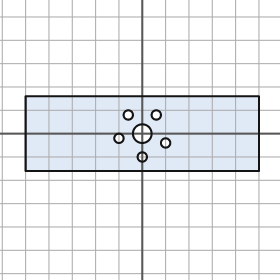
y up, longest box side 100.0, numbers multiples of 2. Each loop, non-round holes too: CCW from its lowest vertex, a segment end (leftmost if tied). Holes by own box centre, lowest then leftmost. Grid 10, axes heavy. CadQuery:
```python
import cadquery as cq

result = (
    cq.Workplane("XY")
    .moveTo(-50.0, -16.0)
    .lineTo(50.0, -16.0)
    .lineTo(50.0, 16.0)
    .lineTo(-50.0, 16.0)
    .close()
    .moveTo(0.0, -10.0)
    .circle(2.0)
    .moveTo(10.0, -4.0)
    .circle(2.0)
    .moveTo(-10.0, -2.0)
    .circle(2.0)
    .moveTo(0.0, 0.0)
    .circle(4.0)
    .moveTo(-6.0, 8.0)
    .circle(2.0)
    .moveTo(6.0, 8.0)
    .circle(2.0)
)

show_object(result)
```